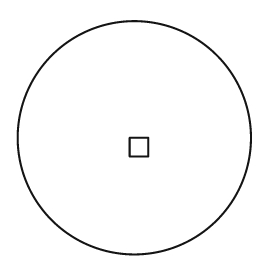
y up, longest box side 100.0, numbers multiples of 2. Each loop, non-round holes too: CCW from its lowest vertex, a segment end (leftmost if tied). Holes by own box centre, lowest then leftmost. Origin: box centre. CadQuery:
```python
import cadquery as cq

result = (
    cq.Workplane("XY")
    .moveTo(0.0, 0.0)
    .circle(50.0)
    .moveTo(-2.0, -8.0)
    .lineTo(6.0, -8.0)
    .lineTo(6.0, 0.0)
    .lineTo(-2.0, 0.0)
    .close()
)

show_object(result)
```